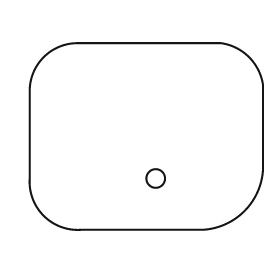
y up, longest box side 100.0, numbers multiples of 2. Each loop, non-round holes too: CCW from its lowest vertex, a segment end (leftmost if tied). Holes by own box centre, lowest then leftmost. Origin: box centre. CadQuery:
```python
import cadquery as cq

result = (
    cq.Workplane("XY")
    .moveTo(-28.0, -40.0)
    .lineTo(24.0, -40.0)
    .threePointArc((42.0, -32.0), (50.0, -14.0))
    .lineTo(50.0, 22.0)
    .threePointArc((44.0, 34.0), (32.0, 40.0))
    .lineTo(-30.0, 40.0)
    .threePointArc((-44.0, 34.0), (-50.0, 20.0))
    .lineTo(-50.0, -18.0)
    .threePointArc((-44.0, -34.0), (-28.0, -40.0))
    .close()
    .moveTo(4.0, -18.0)
    .circle(4.0)
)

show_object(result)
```